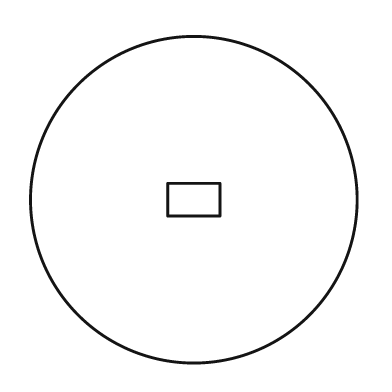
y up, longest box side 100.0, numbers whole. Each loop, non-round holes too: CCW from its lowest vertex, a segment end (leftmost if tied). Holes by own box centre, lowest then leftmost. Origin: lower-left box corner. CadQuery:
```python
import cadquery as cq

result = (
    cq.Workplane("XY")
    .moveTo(50.0, 50.0)
    .circle(50.0)
    .moveTo(42.0, 45.0)
    .lineTo(58.0, 45.0)
    .lineTo(58.0, 55.0)
    .lineTo(42.0, 55.0)
    .close()
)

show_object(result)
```